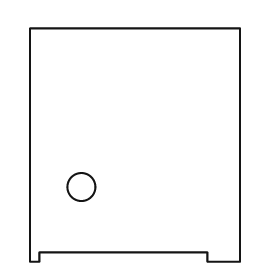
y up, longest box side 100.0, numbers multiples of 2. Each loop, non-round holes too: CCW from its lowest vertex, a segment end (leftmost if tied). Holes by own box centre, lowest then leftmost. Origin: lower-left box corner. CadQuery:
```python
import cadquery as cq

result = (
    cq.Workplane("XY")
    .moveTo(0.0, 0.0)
    .lineTo(4.0, 0.0)
    .lineTo(4.0, 4.0)
    .lineTo(76.0, 4.0)
    .lineTo(76.0, 0.0)
    .lineTo(90.0, 0.0)
    .lineTo(90.0, 100.0)
    .lineTo(0.0, 100.0)
    .close()
    .moveTo(22.0, 32.0)
    .circle(6.0)
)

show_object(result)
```